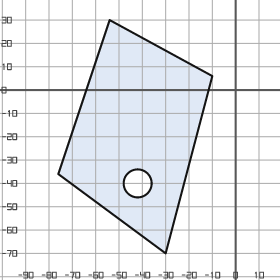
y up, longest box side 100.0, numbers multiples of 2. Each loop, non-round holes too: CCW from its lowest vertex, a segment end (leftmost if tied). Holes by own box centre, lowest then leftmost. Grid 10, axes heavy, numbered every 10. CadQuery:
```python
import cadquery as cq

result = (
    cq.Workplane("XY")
    .moveTo(-30.0, -70.0)
    .lineTo(-10.0, 6.0)
    .lineTo(-54.0, 30.0)
    .lineTo(-76.0, -36.0)
    .close()
    .moveTo(-42.0, -40.0)
    .circle(6.0)
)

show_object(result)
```